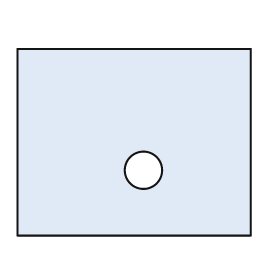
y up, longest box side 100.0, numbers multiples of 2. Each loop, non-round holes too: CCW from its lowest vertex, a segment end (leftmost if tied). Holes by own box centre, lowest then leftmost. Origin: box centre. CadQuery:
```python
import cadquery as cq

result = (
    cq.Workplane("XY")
    .moveTo(-50.0, -40.0)
    .lineTo(50.0, -40.0)
    .lineTo(50.0, 40.0)
    .lineTo(-50.0, 40.0)
    .close()
    .moveTo(4.0, -12.0)
    .circle(8.0)
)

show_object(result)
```